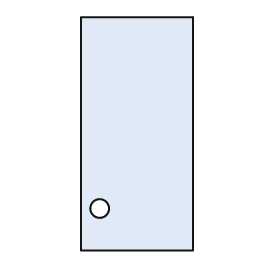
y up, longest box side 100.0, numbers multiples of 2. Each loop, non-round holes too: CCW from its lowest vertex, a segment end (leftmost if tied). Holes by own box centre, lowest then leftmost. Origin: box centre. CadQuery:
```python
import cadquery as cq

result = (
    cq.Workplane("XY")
    .moveTo(-24.0, -50.0)
    .lineTo(24.0, -50.0)
    .lineTo(24.0, 50.0)
    .lineTo(-24.0, 50.0)
    .close()
    .moveTo(-16.0, -32.0)
    .circle(4.0)
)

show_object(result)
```